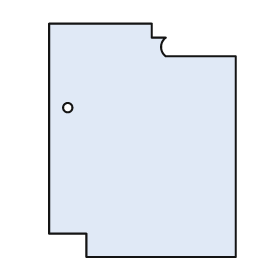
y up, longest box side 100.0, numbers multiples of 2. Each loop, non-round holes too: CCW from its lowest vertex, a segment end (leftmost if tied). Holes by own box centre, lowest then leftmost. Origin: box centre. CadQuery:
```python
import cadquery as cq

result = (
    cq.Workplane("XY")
    .moveTo(-24.0, -50.0)
    .lineTo(40.0, -50.0)
    .lineTo(40.0, 36.0)
    .lineTo(10.0, 36.0)
    .threePointArc((8.0, 40.0), (10.0, 44.0))
    .lineTo(4.0, 44.0)
    .lineTo(4.0, 50.0)
    .lineTo(-40.0, 50.0)
    .lineTo(-40.0, -40.0)
    .lineTo(-24.0, -40.0)
    .close()
    .moveTo(-32.0, 14.0)
    .circle(2.0)
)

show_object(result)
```